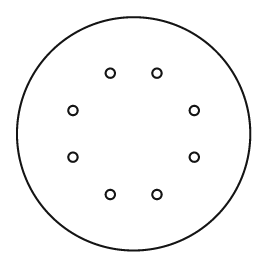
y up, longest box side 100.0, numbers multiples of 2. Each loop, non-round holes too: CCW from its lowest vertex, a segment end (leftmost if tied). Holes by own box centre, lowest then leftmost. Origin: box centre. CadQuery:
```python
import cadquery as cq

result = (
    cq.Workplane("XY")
    .moveTo(0.0, 0.0)
    .circle(50.0)
    .moveTo(-10.0, -26.0)
    .circle(2.0)
    .moveTo(10.0, -26.0)
    .circle(2.0)
    .moveTo(-26.0, -10.0)
    .circle(2.0)
    .moveTo(26.0, -10.0)
    .circle(2.0)
    .moveTo(-26.0, 10.0)
    .circle(2.0)
    .moveTo(26.0, 10.0)
    .circle(2.0)
    .moveTo(-10.0, 26.0)
    .circle(2.0)
    .moveTo(10.0, 26.0)
    .circle(2.0)
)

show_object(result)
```